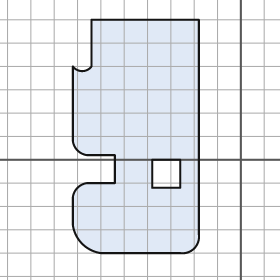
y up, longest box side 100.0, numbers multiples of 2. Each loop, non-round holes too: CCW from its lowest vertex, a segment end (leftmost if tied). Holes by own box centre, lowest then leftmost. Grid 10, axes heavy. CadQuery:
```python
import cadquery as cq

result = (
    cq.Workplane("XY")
    .moveTo(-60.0, -40.0)
    .lineTo(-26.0, -40.0)
    .threePointArc((-20.0, -38.0), (-18.0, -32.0))
    .lineTo(-18.0, 60.0)
    .lineTo(-64.0, 60.0)
    .lineTo(-64.0, 40.0)
    .threePointArc((-68.0, 38.0), (-72.0, 40.0))
    .lineTo(-72.0, 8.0)
    .threePointArc((-70.0, 4.0), (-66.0, 2.0))
    .lineTo(-54.0, 2.0)
    .lineTo(-54.0, -10.0)
    .lineTo(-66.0, -10.0)
    .threePointArc((-70.0, -12.0), (-72.0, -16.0))
    .lineTo(-72.0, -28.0)
    .threePointArc((-68.0, -36.0), (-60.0, -40.0))
    .close()
    .moveTo(-38.0, -12.0)
    .lineTo(-26.0, -12.0)
    .lineTo(-26.0, 0.0)
    .lineTo(-38.0, 0.0)
    .close()
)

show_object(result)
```